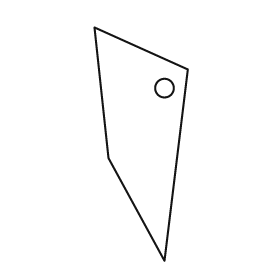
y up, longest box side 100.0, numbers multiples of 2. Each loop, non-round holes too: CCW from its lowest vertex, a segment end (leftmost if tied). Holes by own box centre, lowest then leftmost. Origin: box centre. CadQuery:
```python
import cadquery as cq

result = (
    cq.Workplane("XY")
    .moveTo(10.0, -50.0)
    .lineTo(20.0, 32.0)
    .lineTo(-20.0, 50.0)
    .lineTo(-14.0, -6.0)
    .close()
    .moveTo(10.0, 24.0)
    .circle(4.0)
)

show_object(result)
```